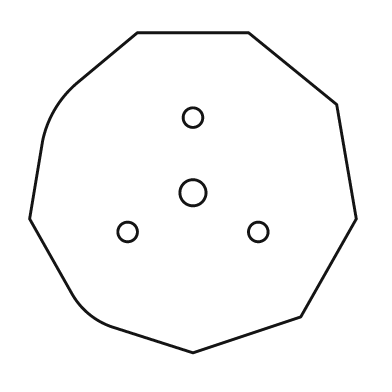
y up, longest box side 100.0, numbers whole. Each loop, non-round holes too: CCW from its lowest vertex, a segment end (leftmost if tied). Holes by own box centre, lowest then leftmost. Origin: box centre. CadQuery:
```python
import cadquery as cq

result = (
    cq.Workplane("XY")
    .moveTo(0.0, -49.0)
    .lineTo(33.0, -38.0)
    .lineTo(50.0, -8.0)
    .lineTo(44.0, 27.0)
    .lineTo(17.0, 49.0)
    .lineTo(-17.0, 49.0)
    .lineTo(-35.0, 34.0)
    .threePointArc((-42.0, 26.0), (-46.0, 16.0))
    .lineTo(-50.0, -8.0)
    .lineTo(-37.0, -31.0)
    .threePointArc((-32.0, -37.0), (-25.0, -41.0))
    .close()
    .moveTo(-20.0, -12.0)
    .circle(3.0)
    .moveTo(20.0, -12.0)
    .circle(3.0)
    .moveTo(0.0, 0.0)
    .circle(4.0)
    .moveTo(0.0, 23.0)
    .circle(3.0)
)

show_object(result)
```